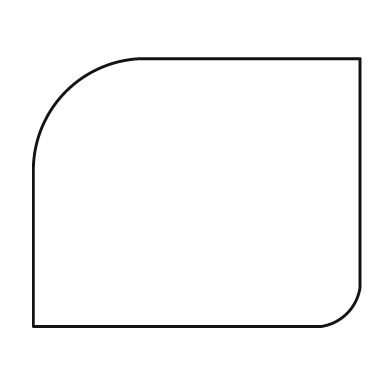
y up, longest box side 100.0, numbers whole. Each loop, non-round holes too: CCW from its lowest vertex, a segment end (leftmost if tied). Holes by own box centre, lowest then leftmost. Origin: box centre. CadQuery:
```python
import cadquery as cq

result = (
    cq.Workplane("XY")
    .moveTo(-50.0, -41.0)
    .lineTo(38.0, -41.0)
    .threePointArc((46.0, -37.0), (50.0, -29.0))
    .lineTo(50.0, 41.0)
    .lineTo(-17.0, 41.0)
    .threePointArc((-40.0, 31.0), (-50.0, 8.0))
    .close()
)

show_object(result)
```